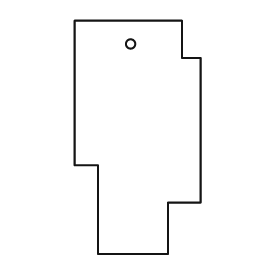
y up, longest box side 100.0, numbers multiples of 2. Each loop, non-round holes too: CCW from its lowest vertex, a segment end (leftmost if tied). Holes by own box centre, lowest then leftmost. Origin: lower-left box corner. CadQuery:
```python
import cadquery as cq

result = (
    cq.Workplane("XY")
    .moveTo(10.0, 0.0)
    .lineTo(40.0, 0.0)
    .lineTo(40.0, 22.0)
    .lineTo(54.0, 22.0)
    .lineTo(54.0, 84.0)
    .lineTo(46.0, 84.0)
    .lineTo(46.0, 100.0)
    .lineTo(0.0, 100.0)
    .lineTo(0.0, 38.0)
    .lineTo(10.0, 38.0)
    .close()
    .moveTo(24.0, 90.0)
    .circle(2.0)
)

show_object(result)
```